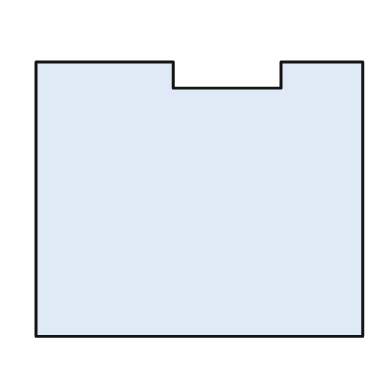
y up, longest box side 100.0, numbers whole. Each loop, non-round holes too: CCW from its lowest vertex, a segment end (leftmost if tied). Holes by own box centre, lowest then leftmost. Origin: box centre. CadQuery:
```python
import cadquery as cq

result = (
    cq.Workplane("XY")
    .moveTo(-50.0, -42.0)
    .lineTo(50.0, -42.0)
    .lineTo(50.0, 42.0)
    .lineTo(25.0, 42.0)
    .lineTo(25.0, 34.0)
    .lineTo(-8.0, 34.0)
    .lineTo(-8.0, 42.0)
    .lineTo(-50.0, 42.0)
    .close()
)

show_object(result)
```